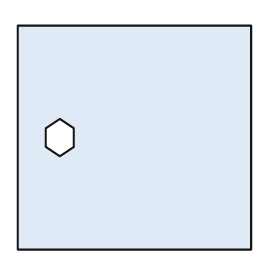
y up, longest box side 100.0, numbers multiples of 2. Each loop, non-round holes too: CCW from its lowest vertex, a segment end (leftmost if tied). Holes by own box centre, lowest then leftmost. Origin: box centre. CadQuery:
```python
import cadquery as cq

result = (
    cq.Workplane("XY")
    .moveTo(-50.0, -48.0)
    .lineTo(50.0, -48.0)
    .lineTo(50.0, 48.0)
    .lineTo(-50.0, 48.0)
    .close()
    .moveTo(-32.0, -8.0)
    .lineTo(-26.0, -4.0)
    .lineTo(-26.0, 4.0)
    .lineTo(-32.0, 8.0)
    .lineTo(-38.0, 4.0)
    .lineTo(-38.0, -4.0)
    .close()
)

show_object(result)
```